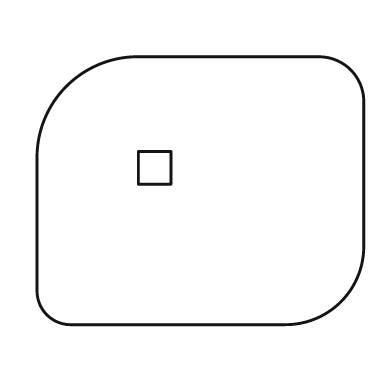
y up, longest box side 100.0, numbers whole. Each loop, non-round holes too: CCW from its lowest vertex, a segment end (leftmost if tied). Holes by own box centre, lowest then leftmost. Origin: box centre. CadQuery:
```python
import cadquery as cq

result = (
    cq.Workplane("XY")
    .moveTo(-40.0, -41.0)
    .lineTo(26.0, -41.0)
    .threePointArc((43.0, -34.0), (50.0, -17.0))
    .lineTo(50.0, 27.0)
    .threePointArc((46.0, 37.0), (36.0, 41.0))
    .lineTo(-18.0, 41.0)
    .threePointArc((-41.0, 32.0), (-50.0, 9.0))
    .lineTo(-50.0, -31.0)
    .threePointArc((-47.0, -38.0), (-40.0, -41.0))
    .close()
    .moveTo(-19.0, 2.0)
    .lineTo(-9.0, 2.0)
    .lineTo(-9.0, 12.0)
    .lineTo(-19.0, 12.0)
    .close()
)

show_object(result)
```